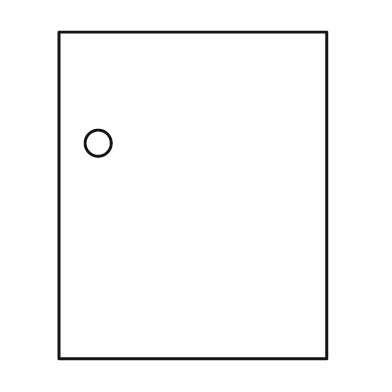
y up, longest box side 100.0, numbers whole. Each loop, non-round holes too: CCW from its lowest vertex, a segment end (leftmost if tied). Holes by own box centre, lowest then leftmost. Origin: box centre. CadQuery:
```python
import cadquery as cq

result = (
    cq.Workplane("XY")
    .moveTo(-41.0, -50.0)
    .lineTo(41.0, -50.0)
    .lineTo(41.0, 50.0)
    .lineTo(-41.0, 50.0)
    .close()
    .moveTo(-29.0, 16.0)
    .circle(4.0)
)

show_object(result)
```